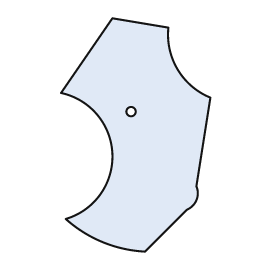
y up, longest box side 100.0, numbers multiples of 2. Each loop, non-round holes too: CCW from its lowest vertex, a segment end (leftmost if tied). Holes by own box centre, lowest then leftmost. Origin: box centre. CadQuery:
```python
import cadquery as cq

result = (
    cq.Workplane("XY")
    .moveTo(4.0, -50.0)
    .lineTo(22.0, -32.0)
    .threePointArc((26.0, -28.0), (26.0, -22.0))
    .lineTo(32.0, 16.0)
    .threePointArc((18.0, 28.0), (14.0, 46.0))
    .lineTo(-10.0, 50.0)
    .lineTo(-32.0, 18.0)
    .threePointArc((-10.0, -8.0), (-30.0, -36.0))
    .threePointArc((-14.0, -46.0), (4.0, -50.0))
    .close()
    .moveTo(-2.0, 10.0)
    .circle(2.0)
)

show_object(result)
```